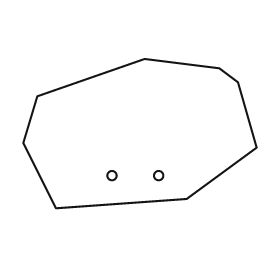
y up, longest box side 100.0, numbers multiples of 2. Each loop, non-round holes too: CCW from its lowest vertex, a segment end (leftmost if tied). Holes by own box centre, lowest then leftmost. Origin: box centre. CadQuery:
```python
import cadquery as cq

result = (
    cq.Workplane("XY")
    .moveTo(-36.0, -32.0)
    .lineTo(20.0, -28.0)
    .lineTo(50.0, -6.0)
    .lineTo(42.0, 22.0)
    .lineTo(34.0, 28.0)
    .lineTo(2.0, 32.0)
    .lineTo(-44.0, 16.0)
    .lineTo(-50.0, -4.0)
    .close()
    .moveTo(-12.0, -18.0)
    .circle(2.0)
    .moveTo(8.0, -18.0)
    .circle(2.0)
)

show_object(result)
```